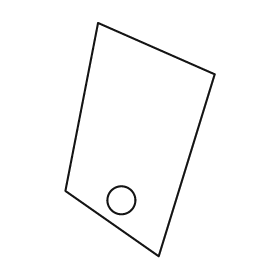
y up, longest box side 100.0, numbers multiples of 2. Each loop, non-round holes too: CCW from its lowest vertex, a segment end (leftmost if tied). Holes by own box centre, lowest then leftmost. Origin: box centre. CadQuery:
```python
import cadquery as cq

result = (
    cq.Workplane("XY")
    .moveTo(8.0, -50.0)
    .lineTo(32.0, 28.0)
    .lineTo(-18.0, 50.0)
    .lineTo(-32.0, -22.0)
    .close()
    .moveTo(-8.0, -26.0)
    .circle(6.0)
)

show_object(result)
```